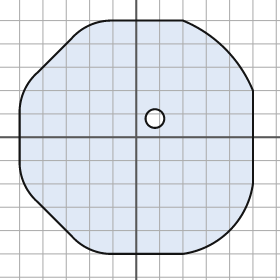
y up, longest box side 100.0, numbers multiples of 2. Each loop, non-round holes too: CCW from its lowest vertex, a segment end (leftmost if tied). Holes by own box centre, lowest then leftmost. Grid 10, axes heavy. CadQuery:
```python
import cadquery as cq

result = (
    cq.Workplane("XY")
    .moveTo(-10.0, -50.0)
    .lineTo(20.0, -50.0)
    .threePointArc((40.0, -40.0), (50.0, -20.0))
    .lineTo(50.0, 20.0)
    .threePointArc((38.0, 38.0), (20.0, 50.0))
    .lineTo(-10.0, 50.0)
    .threePointArc((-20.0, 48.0), (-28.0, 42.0))
    .lineTo(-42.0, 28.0)
    .threePointArc((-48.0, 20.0), (-50.0, 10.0))
    .lineTo(-50.0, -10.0)
    .threePointArc((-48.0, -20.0), (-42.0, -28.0))
    .lineTo(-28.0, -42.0)
    .threePointArc((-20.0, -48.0), (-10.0, -50.0))
    .close()
    .moveTo(8.0, 8.0)
    .circle(4.0)
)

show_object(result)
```